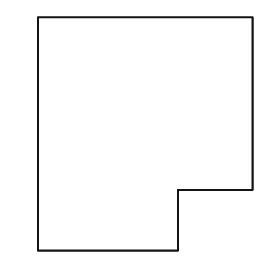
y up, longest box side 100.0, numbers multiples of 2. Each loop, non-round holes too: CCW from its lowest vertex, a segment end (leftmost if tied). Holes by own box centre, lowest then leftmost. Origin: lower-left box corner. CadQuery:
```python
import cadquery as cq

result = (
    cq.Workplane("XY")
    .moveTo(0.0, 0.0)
    .lineTo(60.0, 0.0)
    .lineTo(60.0, 26.0)
    .lineTo(92.0, 26.0)
    .lineTo(92.0, 100.0)
    .lineTo(0.0, 100.0)
    .close()
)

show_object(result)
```